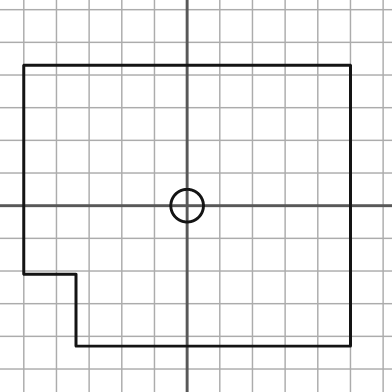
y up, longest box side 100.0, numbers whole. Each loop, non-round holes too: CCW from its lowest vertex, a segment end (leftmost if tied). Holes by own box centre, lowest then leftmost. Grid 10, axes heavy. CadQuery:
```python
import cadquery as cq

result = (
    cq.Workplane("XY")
    .moveTo(-34.0, -43.0)
    .lineTo(50.0, -43.0)
    .lineTo(50.0, 43.0)
    .lineTo(-50.0, 43.0)
    .lineTo(-50.0, -21.0)
    .lineTo(-34.0, -21.0)
    .close()
    .moveTo(0.0, 0.0)
    .circle(5.0)
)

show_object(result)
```